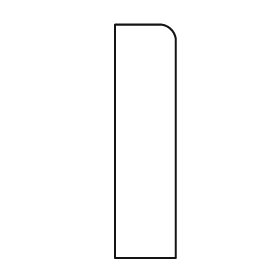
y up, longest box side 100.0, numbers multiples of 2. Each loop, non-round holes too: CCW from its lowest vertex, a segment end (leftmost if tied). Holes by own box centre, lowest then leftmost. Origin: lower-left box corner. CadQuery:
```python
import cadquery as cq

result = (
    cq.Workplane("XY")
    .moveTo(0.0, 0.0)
    .lineTo(26.0, 0.0)
    .lineTo(26.0, 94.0)
    .threePointArc((24.0, 98.0), (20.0, 100.0))
    .lineTo(0.0, 100.0)
    .close()
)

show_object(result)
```